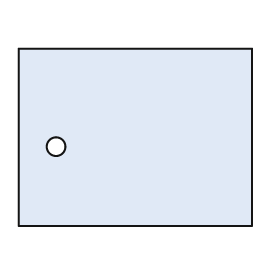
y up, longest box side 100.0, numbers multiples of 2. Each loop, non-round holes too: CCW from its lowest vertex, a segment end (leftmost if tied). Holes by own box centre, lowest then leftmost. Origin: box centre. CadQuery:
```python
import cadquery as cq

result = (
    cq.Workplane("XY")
    .moveTo(-50.0, -38.0)
    .lineTo(50.0, -38.0)
    .lineTo(50.0, 38.0)
    .lineTo(-50.0, 38.0)
    .close()
    .moveTo(-34.0, -4.0)
    .circle(4.0)
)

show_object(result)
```